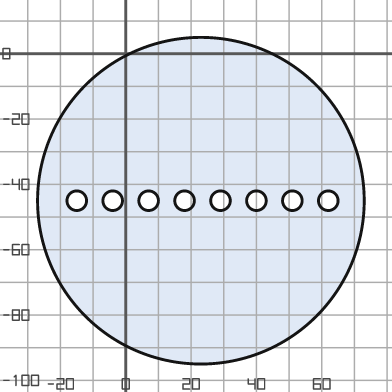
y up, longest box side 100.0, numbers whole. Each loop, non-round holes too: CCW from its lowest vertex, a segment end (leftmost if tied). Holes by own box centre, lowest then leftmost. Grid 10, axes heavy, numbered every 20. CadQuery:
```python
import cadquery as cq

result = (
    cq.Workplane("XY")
    .moveTo(23.0, -45.0)
    .circle(50.0)
    .moveTo(-15.0, -45.0)
    .circle(3.0)
    .moveTo(-4.0, -45.0)
    .circle(3.0)
    .moveTo(7.0, -45.0)
    .circle(3.0)
    .moveTo(18.0, -45.0)
    .circle(3.0)
    .moveTo(29.0, -45.0)
    .circle(3.0)
    .moveTo(40.0, -45.0)
    .circle(3.0)
    .moveTo(51.0, -45.0)
    .circle(3.0)
    .moveTo(62.0, -45.0)
    .circle(3.0)
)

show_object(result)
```